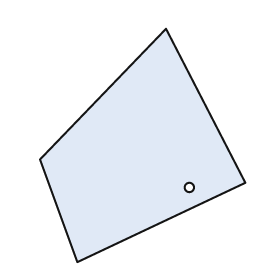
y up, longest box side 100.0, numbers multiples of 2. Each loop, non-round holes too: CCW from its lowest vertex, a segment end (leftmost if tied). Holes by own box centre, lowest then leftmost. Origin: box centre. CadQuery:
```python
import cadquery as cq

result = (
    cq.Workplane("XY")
    .moveTo(-28.0, -50.0)
    .lineTo(44.0, -16.0)
    .lineTo(10.0, 50.0)
    .lineTo(-44.0, -6.0)
    .close()
    .moveTo(20.0, -18.0)
    .circle(2.0)
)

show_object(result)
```